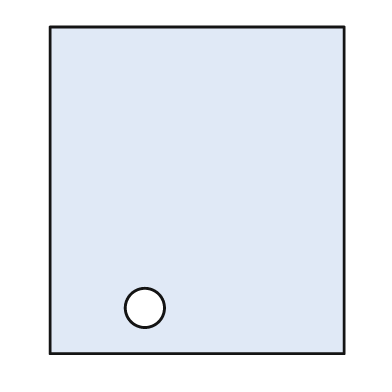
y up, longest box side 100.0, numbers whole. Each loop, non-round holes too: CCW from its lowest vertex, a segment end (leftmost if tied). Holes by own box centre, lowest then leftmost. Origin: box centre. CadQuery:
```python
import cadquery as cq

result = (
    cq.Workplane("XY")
    .moveTo(-45.0, -50.0)
    .lineTo(45.0, -50.0)
    .lineTo(45.0, 50.0)
    .lineTo(-45.0, 50.0)
    .close()
    .moveTo(-16.0, -36.0)
    .circle(6.0)
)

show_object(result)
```